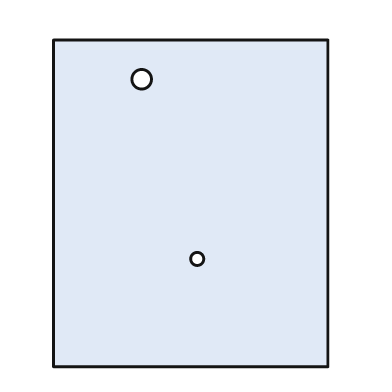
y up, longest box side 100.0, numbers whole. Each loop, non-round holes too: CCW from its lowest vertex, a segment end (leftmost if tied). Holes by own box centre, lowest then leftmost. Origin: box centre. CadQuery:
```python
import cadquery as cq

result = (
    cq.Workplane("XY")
    .moveTo(-42.0, -50.0)
    .lineTo(42.0, -50.0)
    .lineTo(42.0, 50.0)
    .lineTo(-42.0, 50.0)
    .close()
    .moveTo(2.0, -17.0)
    .circle(2.0)
    .moveTo(-15.0, 38.0)
    .circle(3.0)
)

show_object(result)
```